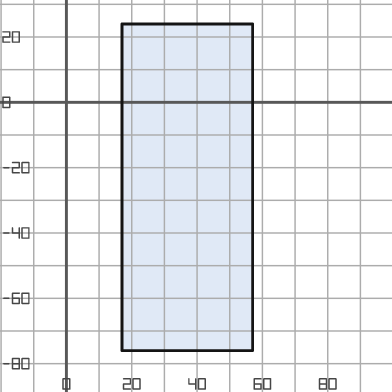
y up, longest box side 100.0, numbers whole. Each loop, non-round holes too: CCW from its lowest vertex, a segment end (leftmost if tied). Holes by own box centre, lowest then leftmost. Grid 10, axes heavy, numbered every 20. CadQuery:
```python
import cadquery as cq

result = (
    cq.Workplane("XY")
    .moveTo(17.0, -76.0)
    .lineTo(57.0, -76.0)
    .lineTo(57.0, 24.0)
    .lineTo(17.0, 24.0)
    .close()
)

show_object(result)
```